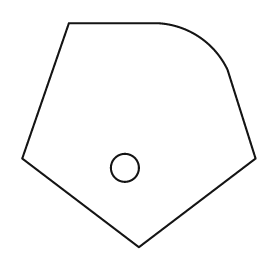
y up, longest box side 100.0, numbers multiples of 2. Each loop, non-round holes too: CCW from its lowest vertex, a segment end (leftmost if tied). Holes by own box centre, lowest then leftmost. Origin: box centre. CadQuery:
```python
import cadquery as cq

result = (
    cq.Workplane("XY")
    .moveTo(0.0, -48.0)
    .lineTo(50.0, -10.0)
    .lineTo(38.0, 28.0)
    .threePointArc((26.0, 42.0), (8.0, 48.0))
    .lineTo(-30.0, 48.0)
    .lineTo(-50.0, -10.0)
    .close()
    .moveTo(-6.0, -14.0)
    .circle(6.0)
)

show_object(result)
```